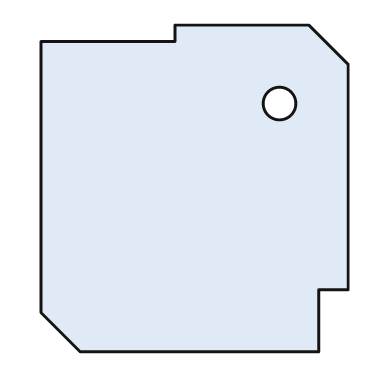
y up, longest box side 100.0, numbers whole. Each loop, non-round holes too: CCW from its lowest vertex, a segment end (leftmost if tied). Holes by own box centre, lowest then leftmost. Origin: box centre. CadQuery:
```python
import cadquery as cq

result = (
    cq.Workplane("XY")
    .moveTo(-35.0, -50.0)
    .lineTo(38.0, -50.0)
    .lineTo(38.0, -31.0)
    .lineTo(47.0, -31.0)
    .lineTo(47.0, 38.0)
    .lineTo(35.0, 50.0)
    .lineTo(-6.0, 50.0)
    .lineTo(-6.0, 45.0)
    .lineTo(-47.0, 45.0)
    .lineTo(-47.0, -38.0)
    .close()
    .moveTo(26.0, 26.0)
    .circle(5.0)
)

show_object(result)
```